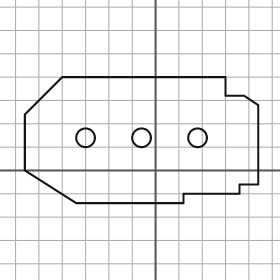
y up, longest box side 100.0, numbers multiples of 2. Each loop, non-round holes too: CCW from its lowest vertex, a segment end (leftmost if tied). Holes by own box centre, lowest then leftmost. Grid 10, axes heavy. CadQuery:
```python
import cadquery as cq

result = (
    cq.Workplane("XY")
    .moveTo(-34.0, -14.0)
    .lineTo(12.0, -14.0)
    .lineTo(12.0, -10.0)
    .lineTo(36.0, -10.0)
    .lineTo(36.0, -6.0)
    .lineTo(44.0, -6.0)
    .lineTo(44.0, 28.0)
    .lineTo(38.0, 32.0)
    .lineTo(30.0, 32.0)
    .lineTo(30.0, 40.0)
    .lineTo(-40.0, 40.0)
    .lineTo(-56.0, 24.0)
    .lineTo(-56.0, 0.0)
    .close()
    .moveTo(-30.0, 14.0)
    .circle(4.0)
    .moveTo(-6.0, 14.0)
    .circle(4.0)
    .moveTo(18.0, 14.0)
    .circle(4.0)
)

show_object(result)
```